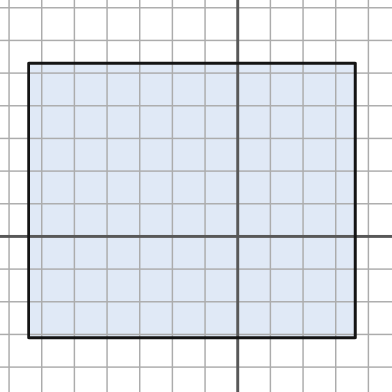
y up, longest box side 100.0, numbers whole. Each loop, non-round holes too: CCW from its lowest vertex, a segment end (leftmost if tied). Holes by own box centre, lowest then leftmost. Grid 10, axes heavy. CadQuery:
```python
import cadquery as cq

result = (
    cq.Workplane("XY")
    .moveTo(-64.0, -31.0)
    .lineTo(36.0, -31.0)
    .lineTo(36.0, 53.0)
    .lineTo(-64.0, 53.0)
    .close()
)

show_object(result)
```